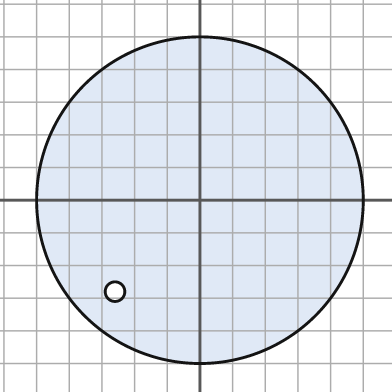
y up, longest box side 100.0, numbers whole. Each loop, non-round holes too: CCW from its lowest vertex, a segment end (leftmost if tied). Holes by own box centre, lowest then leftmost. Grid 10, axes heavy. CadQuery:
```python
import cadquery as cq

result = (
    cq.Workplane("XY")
    .moveTo(0.0, 0.0)
    .circle(50.0)
    .moveTo(-26.0, -28.0)
    .circle(3.0)
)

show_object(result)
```